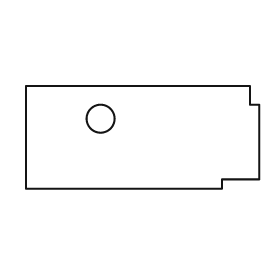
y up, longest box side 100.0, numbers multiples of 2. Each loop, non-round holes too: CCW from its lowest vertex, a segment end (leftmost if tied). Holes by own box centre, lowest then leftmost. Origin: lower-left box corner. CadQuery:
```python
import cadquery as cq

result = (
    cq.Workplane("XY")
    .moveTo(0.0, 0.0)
    .lineTo(84.0, 0.0)
    .lineTo(84.0, 4.0)
    .lineTo(100.0, 4.0)
    .lineTo(100.0, 36.0)
    .lineTo(96.0, 36.0)
    .lineTo(96.0, 44.0)
    .lineTo(0.0, 44.0)
    .close()
    .moveTo(32.0, 30.0)
    .circle(6.0)
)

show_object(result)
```